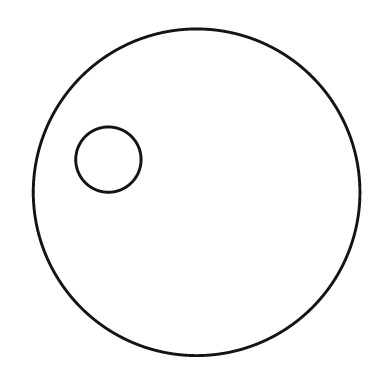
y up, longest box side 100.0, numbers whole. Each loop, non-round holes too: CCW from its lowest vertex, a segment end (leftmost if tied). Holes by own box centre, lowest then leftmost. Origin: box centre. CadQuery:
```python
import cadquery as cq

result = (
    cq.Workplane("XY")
    .moveTo(0.0, 0.0)
    .circle(50.0)
    .moveTo(-27.0, 10.0)
    .circle(10.0)
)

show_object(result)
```